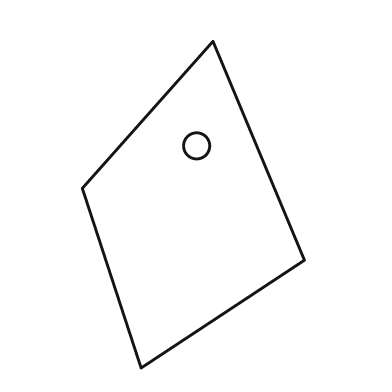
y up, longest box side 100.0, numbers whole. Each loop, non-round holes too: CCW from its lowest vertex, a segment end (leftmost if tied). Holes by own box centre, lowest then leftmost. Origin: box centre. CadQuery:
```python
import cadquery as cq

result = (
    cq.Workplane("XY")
    .moveTo(-16.0, -50.0)
    .lineTo(34.0, -17.0)
    .lineTo(6.0, 50.0)
    .lineTo(-34.0, 5.0)
    .close()
    .moveTo(1.0, 18.0)
    .circle(4.0)
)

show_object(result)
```